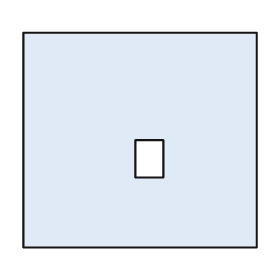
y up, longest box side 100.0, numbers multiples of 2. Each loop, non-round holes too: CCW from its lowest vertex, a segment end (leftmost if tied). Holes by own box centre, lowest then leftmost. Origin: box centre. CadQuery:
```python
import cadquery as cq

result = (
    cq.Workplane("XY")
    .moveTo(-50.0, -46.0)
    .lineTo(50.0, -46.0)
    .lineTo(50.0, 46.0)
    .lineTo(-50.0, 46.0)
    .close()
    .moveTo(-2.0, -16.0)
    .lineTo(10.0, -16.0)
    .lineTo(10.0, 0.0)
    .lineTo(-2.0, 0.0)
    .close()
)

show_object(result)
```